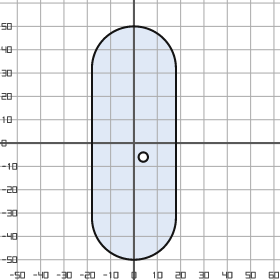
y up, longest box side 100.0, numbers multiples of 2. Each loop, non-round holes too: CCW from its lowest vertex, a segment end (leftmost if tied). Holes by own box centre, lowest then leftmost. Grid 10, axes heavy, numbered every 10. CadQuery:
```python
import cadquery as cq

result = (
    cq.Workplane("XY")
    .moveTo(-18.0, -32.0)
    .threePointArc((0.0, -50.0), (18.0, -32.0))
    .lineTo(18.0, 32.0)
    .threePointArc((0.0, 50.0), (-18.0, 32.0))
    .close()
    .moveTo(4.0, -6.0)
    .circle(2.0)
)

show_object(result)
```